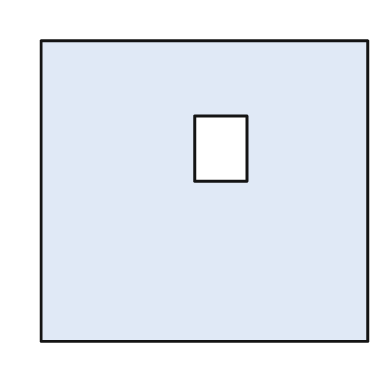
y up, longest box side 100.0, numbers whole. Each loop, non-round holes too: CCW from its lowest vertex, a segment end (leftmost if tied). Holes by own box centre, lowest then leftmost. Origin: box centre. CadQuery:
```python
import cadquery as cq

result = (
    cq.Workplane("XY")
    .moveTo(-50.0, -46.0)
    .lineTo(50.0, -46.0)
    .lineTo(50.0, 46.0)
    .lineTo(-50.0, 46.0)
    .close()
    .moveTo(-3.0, 3.0)
    .lineTo(13.0, 3.0)
    .lineTo(13.0, 23.0)
    .lineTo(-3.0, 23.0)
    .close()
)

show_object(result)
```